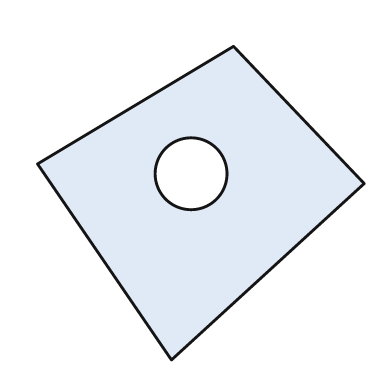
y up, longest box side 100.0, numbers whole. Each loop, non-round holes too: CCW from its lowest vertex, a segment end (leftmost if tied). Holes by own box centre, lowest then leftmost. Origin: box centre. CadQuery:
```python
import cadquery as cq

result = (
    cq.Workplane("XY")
    .moveTo(-9.0, -48.0)
    .lineTo(50.0, 6.0)
    .lineTo(10.0, 48.0)
    .lineTo(-50.0, 12.0)
    .close()
    .moveTo(-3.0, 9.0)
    .circle(11.0)
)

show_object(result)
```